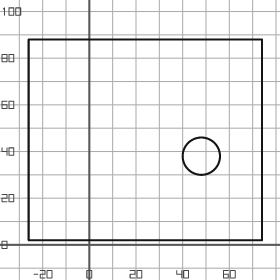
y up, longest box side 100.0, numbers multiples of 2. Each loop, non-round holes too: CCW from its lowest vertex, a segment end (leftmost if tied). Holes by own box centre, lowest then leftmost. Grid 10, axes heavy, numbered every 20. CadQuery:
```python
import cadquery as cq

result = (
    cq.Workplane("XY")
    .moveTo(-26.0, 2.0)
    .lineTo(74.0, 2.0)
    .lineTo(74.0, 88.0)
    .lineTo(-26.0, 88.0)
    .close()
    .moveTo(48.0, 38.0)
    .circle(8.0)
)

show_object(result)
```